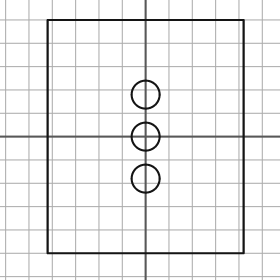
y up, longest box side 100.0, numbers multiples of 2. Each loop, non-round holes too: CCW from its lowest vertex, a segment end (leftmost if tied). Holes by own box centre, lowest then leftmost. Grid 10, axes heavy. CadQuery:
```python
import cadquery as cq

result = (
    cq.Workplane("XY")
    .moveTo(-42.0, -50.0)
    .lineTo(42.0, -50.0)
    .lineTo(42.0, 50.0)
    .lineTo(-42.0, 50.0)
    .close()
    .moveTo(0.0, -18.0)
    .circle(6.0)
    .moveTo(0.0, 0.0)
    .circle(6.0)
    .moveTo(0.0, 18.0)
    .circle(6.0)
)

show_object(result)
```